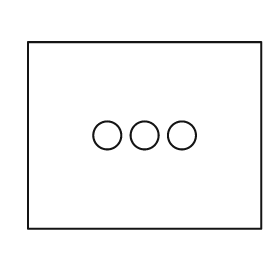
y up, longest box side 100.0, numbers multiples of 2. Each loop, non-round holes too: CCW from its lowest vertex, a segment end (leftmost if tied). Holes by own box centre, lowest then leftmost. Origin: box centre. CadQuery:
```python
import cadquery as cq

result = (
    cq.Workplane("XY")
    .moveTo(-50.0, -40.0)
    .lineTo(50.0, -40.0)
    .lineTo(50.0, 40.0)
    .lineTo(-50.0, 40.0)
    .close()
    .moveTo(-16.0, 0.0)
    .circle(6.0)
    .moveTo(0.0, 0.0)
    .circle(6.0)
    .moveTo(16.0, 0.0)
    .circle(6.0)
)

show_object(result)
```